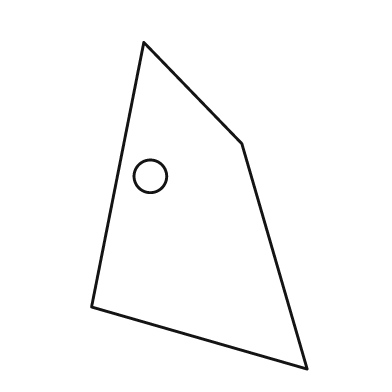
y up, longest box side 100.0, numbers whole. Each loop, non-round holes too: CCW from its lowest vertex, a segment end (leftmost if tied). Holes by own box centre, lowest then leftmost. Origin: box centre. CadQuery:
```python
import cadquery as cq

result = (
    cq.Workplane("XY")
    .moveTo(33.0, -50.0)
    .lineTo(13.0, 19.0)
    .lineTo(-17.0, 50.0)
    .lineTo(-33.0, -31.0)
    .close()
    .moveTo(-15.0, 9.0)
    .circle(5.0)
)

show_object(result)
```